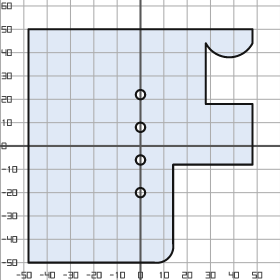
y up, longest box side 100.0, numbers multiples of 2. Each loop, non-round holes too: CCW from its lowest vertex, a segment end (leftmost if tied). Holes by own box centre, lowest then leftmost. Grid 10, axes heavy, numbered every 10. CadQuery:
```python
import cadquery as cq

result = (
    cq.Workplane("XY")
    .moveTo(-48.0, -50.0)
    .lineTo(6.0, -50.0)
    .threePointArc((12.0, -48.0), (14.0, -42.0))
    .lineTo(14.0, -8.0)
    .lineTo(48.0, -8.0)
    .lineTo(48.0, 18.0)
    .lineTo(28.0, 18.0)
    .lineTo(28.0, 44.0)
    .threePointArc((38.0, 38.0), (48.0, 44.0))
    .lineTo(48.0, 50.0)
    .lineTo(-48.0, 50.0)
    .close()
    .moveTo(0.0, -20.0)
    .circle(2.0)
    .moveTo(0.0, -6.0)
    .circle(2.0)
    .moveTo(0.0, 8.0)
    .circle(2.0)
    .moveTo(0.0, 22.0)
    .circle(2.0)
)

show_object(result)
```